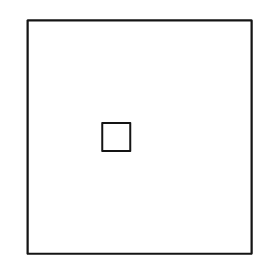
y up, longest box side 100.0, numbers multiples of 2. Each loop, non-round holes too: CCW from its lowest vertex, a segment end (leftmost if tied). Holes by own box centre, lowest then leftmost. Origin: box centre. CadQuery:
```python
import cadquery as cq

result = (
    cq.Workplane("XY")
    .moveTo(-48.0, -50.0)
    .lineTo(48.0, -50.0)
    .lineTo(48.0, 50.0)
    .lineTo(-48.0, 50.0)
    .close()
    .moveTo(-16.0, -6.0)
    .lineTo(-4.0, -6.0)
    .lineTo(-4.0, 6.0)
    .lineTo(-16.0, 6.0)
    .close()
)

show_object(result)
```